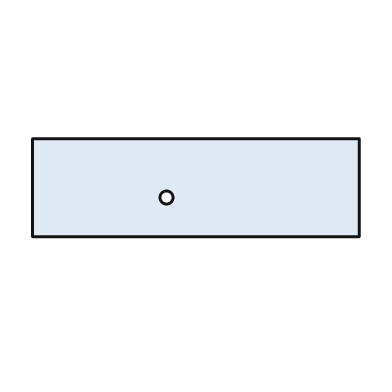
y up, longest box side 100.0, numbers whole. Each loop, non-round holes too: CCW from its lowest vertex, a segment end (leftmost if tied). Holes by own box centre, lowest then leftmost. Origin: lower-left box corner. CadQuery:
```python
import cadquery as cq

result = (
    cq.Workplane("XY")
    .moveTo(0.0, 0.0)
    .lineTo(100.0, 0.0)
    .lineTo(100.0, 30.0)
    .lineTo(0.0, 30.0)
    .close()
    .moveTo(41.0, 12.0)
    .circle(2.0)
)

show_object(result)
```